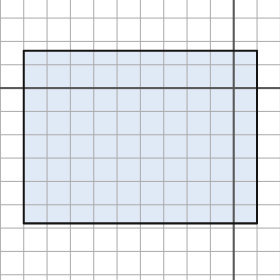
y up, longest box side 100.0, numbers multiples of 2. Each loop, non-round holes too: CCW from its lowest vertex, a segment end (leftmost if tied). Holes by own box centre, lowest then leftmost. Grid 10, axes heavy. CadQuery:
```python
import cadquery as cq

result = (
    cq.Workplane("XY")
    .moveTo(-90.0, -58.0)
    .lineTo(10.0, -58.0)
    .lineTo(10.0, 16.0)
    .lineTo(-90.0, 16.0)
    .close()
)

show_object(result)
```